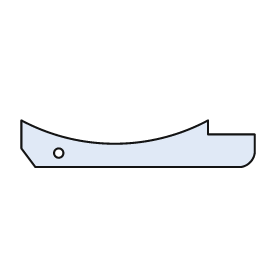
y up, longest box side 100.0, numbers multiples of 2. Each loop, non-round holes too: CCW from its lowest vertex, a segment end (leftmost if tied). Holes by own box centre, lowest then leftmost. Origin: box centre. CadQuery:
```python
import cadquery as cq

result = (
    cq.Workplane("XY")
    .moveTo(-44.0, -10.0)
    .lineTo(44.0, -10.0)
    .threePointArc((48.0, -8.0), (50.0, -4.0))
    .lineTo(50.0, 4.0)
    .lineTo(30.0, 4.0)
    .lineTo(30.0, 10.0)
    .threePointArc((-10.0, 0.0), (-50.0, 10.0))
    .lineTo(-50.0, -2.0)
    .close()
    .moveTo(-34.0, -4.0)
    .circle(2.0)
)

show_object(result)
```